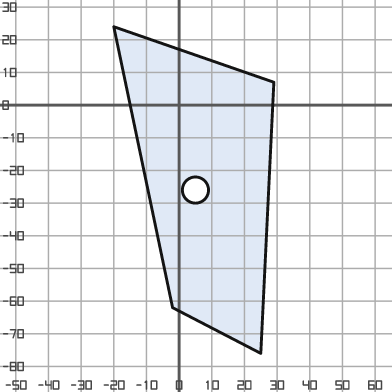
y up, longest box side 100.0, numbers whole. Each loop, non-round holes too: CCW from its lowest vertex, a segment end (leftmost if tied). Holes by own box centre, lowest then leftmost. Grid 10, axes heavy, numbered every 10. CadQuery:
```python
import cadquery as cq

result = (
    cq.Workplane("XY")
    .moveTo(25.0, -76.0)
    .lineTo(29.0, 7.0)
    .lineTo(-20.0, 24.0)
    .lineTo(-2.0, -62.0)
    .close()
    .moveTo(5.0, -26.0)
    .circle(4.0)
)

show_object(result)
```